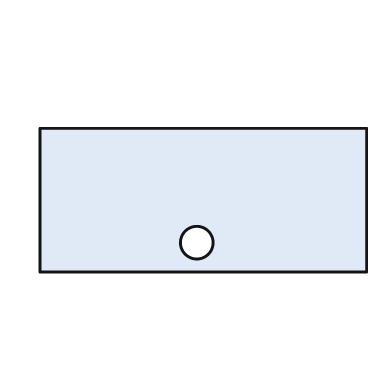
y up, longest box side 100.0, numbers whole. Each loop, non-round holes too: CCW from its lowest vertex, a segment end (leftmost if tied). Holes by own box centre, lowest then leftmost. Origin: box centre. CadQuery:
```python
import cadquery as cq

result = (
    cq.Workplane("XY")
    .moveTo(-50.0, -22.0)
    .lineTo(50.0, -22.0)
    .lineTo(50.0, 22.0)
    .lineTo(-50.0, 22.0)
    .close()
    .moveTo(-2.0, -13.0)
    .circle(5.0)
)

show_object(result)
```